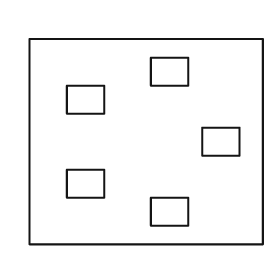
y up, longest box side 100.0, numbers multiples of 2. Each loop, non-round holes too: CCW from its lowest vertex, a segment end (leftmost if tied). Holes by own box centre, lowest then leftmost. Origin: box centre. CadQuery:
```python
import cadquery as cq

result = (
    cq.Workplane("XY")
    .moveTo(-50.0, -44.0)
    .lineTo(50.0, -44.0)
    .lineTo(50.0, 44.0)
    .lineTo(-50.0, 44.0)
    .close()
    .moveTo(2.0, -36.0)
    .lineTo(18.0, -36.0)
    .lineTo(18.0, -24.0)
    .lineTo(2.0, -24.0)
    .close()
    .moveTo(-34.0, -24.0)
    .lineTo(-18.0, -24.0)
    .lineTo(-18.0, -12.0)
    .lineTo(-34.0, -12.0)
    .close()
    .moveTo(24.0, -6.0)
    .lineTo(40.0, -6.0)
    .lineTo(40.0, 6.0)
    .lineTo(24.0, 6.0)
    .close()
    .moveTo(-34.0, 12.0)
    .lineTo(-18.0, 12.0)
    .lineTo(-18.0, 24.0)
    .lineTo(-34.0, 24.0)
    .close()
    .moveTo(2.0, 24.0)
    .lineTo(18.0, 24.0)
    .lineTo(18.0, 36.0)
    .lineTo(2.0, 36.0)
    .close()
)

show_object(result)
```